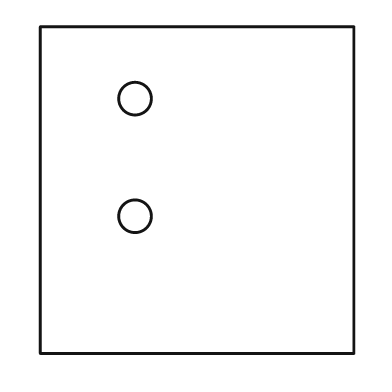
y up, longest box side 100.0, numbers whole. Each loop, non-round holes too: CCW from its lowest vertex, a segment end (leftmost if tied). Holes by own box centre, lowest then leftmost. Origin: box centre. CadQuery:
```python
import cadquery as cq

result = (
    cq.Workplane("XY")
    .moveTo(-48.0, -50.0)
    .lineTo(48.0, -50.0)
    .lineTo(48.0, 50.0)
    .lineTo(-48.0, 50.0)
    .close()
    .moveTo(-19.0, -8.0)
    .circle(5.0)
    .moveTo(-19.0, 28.0)
    .circle(5.0)
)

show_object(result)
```